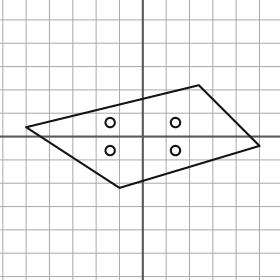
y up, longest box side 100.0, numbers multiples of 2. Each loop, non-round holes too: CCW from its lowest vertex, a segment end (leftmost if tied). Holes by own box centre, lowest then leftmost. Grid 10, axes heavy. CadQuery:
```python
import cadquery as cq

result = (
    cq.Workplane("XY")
    .moveTo(-10.0, -22.0)
    .lineTo(50.0, -4.0)
    .lineTo(24.0, 22.0)
    .lineTo(-50.0, 4.0)
    .close()
    .moveTo(-14.0, -6.0)
    .circle(2.0)
    .moveTo(14.0, -6.0)
    .circle(2.0)
    .moveTo(-14.0, 6.0)
    .circle(2.0)
    .moveTo(14.0, 6.0)
    .circle(2.0)
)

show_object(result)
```